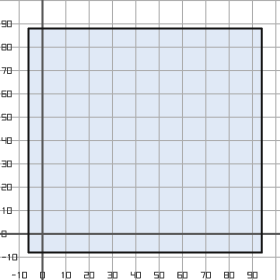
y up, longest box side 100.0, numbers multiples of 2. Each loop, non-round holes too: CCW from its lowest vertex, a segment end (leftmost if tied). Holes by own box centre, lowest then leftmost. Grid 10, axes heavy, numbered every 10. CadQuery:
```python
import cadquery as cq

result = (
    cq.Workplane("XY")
    .moveTo(-6.0, -8.0)
    .lineTo(94.0, -8.0)
    .lineTo(94.0, 88.0)
    .lineTo(-6.0, 88.0)
    .close()
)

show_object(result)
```